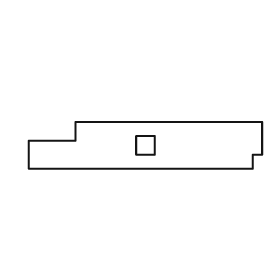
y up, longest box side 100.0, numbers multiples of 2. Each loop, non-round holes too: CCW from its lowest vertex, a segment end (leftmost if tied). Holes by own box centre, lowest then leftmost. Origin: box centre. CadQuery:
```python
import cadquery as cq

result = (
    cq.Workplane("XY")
    .moveTo(-50.0, -10.0)
    .lineTo(46.0, -10.0)
    .lineTo(46.0, -4.0)
    .lineTo(50.0, -4.0)
    .lineTo(50.0, 10.0)
    .lineTo(-30.0, 10.0)
    .lineTo(-30.0, 2.0)
    .lineTo(-50.0, 2.0)
    .close()
    .moveTo(-4.0, -4.0)
    .lineTo(4.0, -4.0)
    .lineTo(4.0, 4.0)
    .lineTo(-4.0, 4.0)
    .close()
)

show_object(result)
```